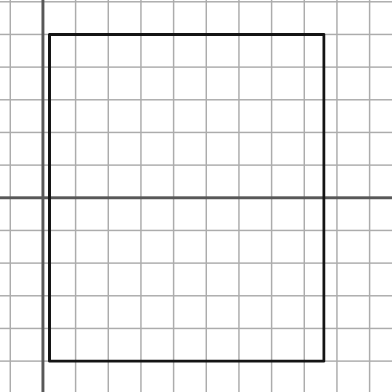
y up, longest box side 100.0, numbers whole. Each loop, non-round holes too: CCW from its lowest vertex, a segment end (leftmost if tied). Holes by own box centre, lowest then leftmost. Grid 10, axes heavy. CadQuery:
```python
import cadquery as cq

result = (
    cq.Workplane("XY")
    .moveTo(2.0, -50.0)
    .lineTo(86.0, -50.0)
    .lineTo(86.0, 50.0)
    .lineTo(2.0, 50.0)
    .close()
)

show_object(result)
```